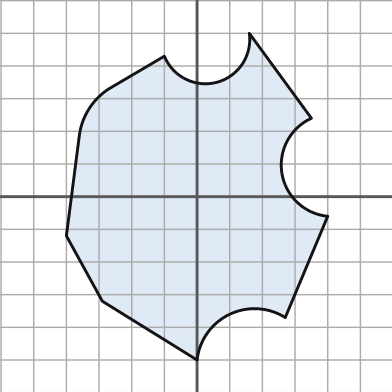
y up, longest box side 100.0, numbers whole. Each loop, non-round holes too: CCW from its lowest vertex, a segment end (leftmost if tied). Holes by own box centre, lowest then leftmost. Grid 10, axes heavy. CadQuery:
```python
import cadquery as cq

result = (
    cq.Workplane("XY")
    .moveTo(0.0, -50.0)
    .threePointArc((10.0, -36.0), (27.0, -37.0))
    .lineTo(40.0, -6.0)
    .threePointArc((26.0, 7.0), (35.0, 24.0))
    .lineTo(16.0, 50.0)
    .threePointArc((6.0, 35.0), (-10.0, 43.0))
    .lineTo(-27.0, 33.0)
    .threePointArc((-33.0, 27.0), (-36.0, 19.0))
    .lineTo(-40.0, -12.0)
    .lineTo(-29.0, -32.0)
    .close()
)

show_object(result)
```